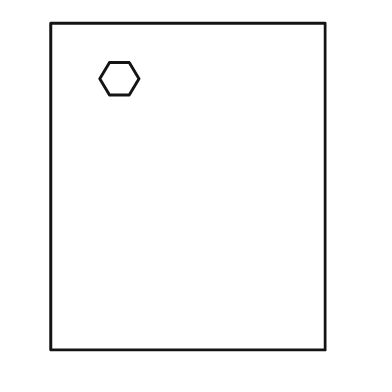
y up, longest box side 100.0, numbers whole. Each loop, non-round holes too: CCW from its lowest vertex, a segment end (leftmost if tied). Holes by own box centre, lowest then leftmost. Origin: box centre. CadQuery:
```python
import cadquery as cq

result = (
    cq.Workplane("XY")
    .moveTo(-42.0, -50.0)
    .lineTo(42.0, -50.0)
    .lineTo(42.0, 50.0)
    .lineTo(-42.0, 50.0)
    .close()
    .moveTo(-24.0, 28.0)
    .lineTo(-18.0, 28.0)
    .lineTo(-15.0, 33.0)
    .lineTo(-18.0, 38.0)
    .lineTo(-24.0, 38.0)
    .lineTo(-27.0, 33.0)
    .close()
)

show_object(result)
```